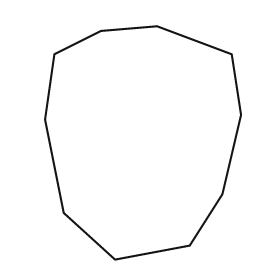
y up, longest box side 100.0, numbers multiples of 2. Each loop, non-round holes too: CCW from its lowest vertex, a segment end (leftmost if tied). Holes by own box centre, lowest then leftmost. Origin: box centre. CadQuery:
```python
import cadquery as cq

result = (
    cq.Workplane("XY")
    .moveTo(-12.0, -50.0)
    .lineTo(20.0, -44.0)
    .lineTo(34.0, -22.0)
    .lineTo(42.0, 12.0)
    .lineTo(38.0, 38.0)
    .lineTo(6.0, 50.0)
    .lineTo(-18.0, 48.0)
    .lineTo(-38.0, 38.0)
    .lineTo(-42.0, 10.0)
    .lineTo(-34.0, -30.0)
    .close()
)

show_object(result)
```